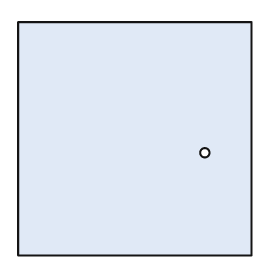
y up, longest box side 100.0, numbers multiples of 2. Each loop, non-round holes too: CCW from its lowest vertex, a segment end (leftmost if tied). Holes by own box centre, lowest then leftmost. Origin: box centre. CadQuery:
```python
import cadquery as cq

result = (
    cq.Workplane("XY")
    .moveTo(-50.0, -50.0)
    .lineTo(50.0, -50.0)
    .lineTo(50.0, 50.0)
    .lineTo(-50.0, 50.0)
    .close()
    .moveTo(30.0, -6.0)
    .circle(2.0)
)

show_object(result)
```